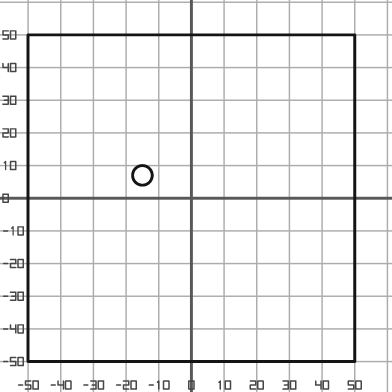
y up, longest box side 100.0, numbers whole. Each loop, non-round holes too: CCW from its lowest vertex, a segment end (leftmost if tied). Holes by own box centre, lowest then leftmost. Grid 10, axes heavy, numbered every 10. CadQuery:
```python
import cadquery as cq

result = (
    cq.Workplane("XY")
    .moveTo(-50.0, -50.0)
    .lineTo(50.0, -50.0)
    .lineTo(50.0, 50.0)
    .lineTo(-50.0, 50.0)
    .close()
    .moveTo(-15.0, 7.0)
    .circle(3.0)
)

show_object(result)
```